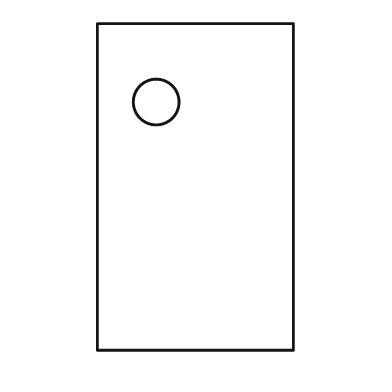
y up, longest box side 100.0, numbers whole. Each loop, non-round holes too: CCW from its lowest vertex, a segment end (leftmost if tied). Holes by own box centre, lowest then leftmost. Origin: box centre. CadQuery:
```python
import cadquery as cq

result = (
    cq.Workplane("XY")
    .moveTo(-30.0, -50.0)
    .lineTo(30.0, -50.0)
    .lineTo(30.0, 50.0)
    .lineTo(-30.0, 50.0)
    .close()
    .moveTo(-12.0, 26.0)
    .circle(7.0)
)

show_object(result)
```